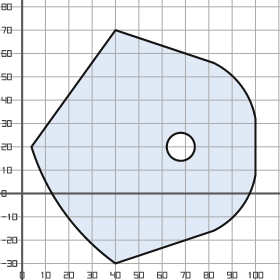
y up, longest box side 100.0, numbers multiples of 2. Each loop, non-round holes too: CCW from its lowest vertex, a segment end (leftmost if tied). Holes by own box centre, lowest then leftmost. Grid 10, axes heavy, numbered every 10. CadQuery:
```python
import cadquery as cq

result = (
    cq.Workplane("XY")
    .moveTo(40.0, -30.0)
    .lineTo(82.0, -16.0)
    .threePointArc((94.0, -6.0), (100.0, 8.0))
    .lineTo(100.0, 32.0)
    .threePointArc((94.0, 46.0), (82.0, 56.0))
    .lineTo(40.0, 70.0)
    .lineTo(4.0, 20.0)
    .threePointArc((18.0, -8.0), (40.0, -30.0))
    .close()
    .moveTo(68.0, 20.0)
    .circle(6.0)
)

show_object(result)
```